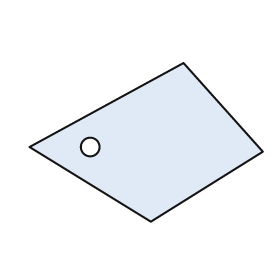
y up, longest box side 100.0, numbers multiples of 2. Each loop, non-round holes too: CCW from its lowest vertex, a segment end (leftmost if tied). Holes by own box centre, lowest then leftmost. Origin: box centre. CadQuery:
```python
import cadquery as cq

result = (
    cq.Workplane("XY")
    .moveTo(2.0, -34.0)
    .lineTo(50.0, -4.0)
    .lineTo(16.0, 34.0)
    .lineTo(-50.0, -2.0)
    .close()
    .moveTo(-24.0, -2.0)
    .circle(4.0)
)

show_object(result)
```